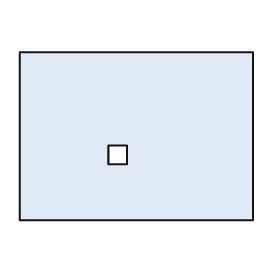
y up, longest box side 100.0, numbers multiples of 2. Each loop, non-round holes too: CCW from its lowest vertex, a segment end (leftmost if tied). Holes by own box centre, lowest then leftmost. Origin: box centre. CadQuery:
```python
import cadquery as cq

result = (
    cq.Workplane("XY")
    .moveTo(-50.0, -36.0)
    .lineTo(50.0, -36.0)
    .lineTo(50.0, 36.0)
    .lineTo(-50.0, 36.0)
    .close()
    .moveTo(-12.0, -12.0)
    .lineTo(-4.0, -12.0)
    .lineTo(-4.0, -4.0)
    .lineTo(-12.0, -4.0)
    .close()
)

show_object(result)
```